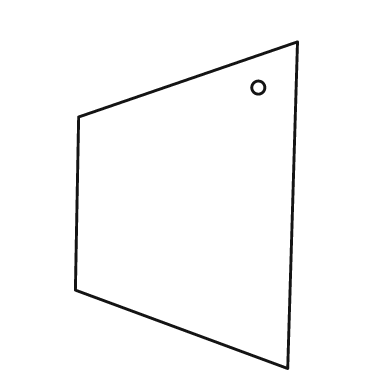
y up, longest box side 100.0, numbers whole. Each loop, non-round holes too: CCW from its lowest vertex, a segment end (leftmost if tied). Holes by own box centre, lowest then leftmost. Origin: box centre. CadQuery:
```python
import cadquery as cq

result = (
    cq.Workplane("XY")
    .moveTo(31.0, -50.0)
    .lineTo(34.0, 50.0)
    .lineTo(-33.0, 27.0)
    .lineTo(-34.0, -26.0)
    .close()
    .moveTo(22.0, 36.0)
    .circle(2.0)
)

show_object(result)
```